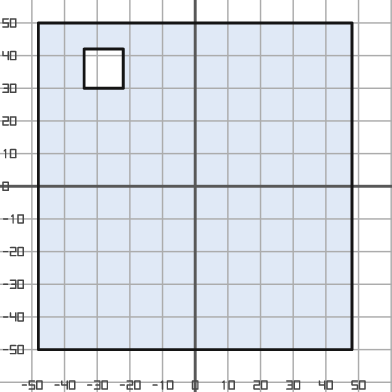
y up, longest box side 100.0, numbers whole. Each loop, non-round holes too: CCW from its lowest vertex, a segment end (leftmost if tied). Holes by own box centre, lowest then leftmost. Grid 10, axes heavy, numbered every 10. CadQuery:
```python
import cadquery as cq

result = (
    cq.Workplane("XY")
    .moveTo(-48.0, -50.0)
    .lineTo(48.0, -50.0)
    .lineTo(48.0, 50.0)
    .lineTo(-48.0, 50.0)
    .close()
    .moveTo(-34.0, 30.0)
    .lineTo(-22.0, 30.0)
    .lineTo(-22.0, 42.0)
    .lineTo(-34.0, 42.0)
    .close()
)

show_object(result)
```